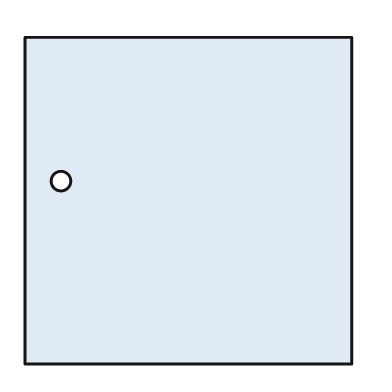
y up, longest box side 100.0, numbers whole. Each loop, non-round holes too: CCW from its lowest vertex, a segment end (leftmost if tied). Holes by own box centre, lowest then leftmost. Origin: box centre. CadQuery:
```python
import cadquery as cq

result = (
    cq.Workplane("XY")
    .moveTo(-50.0, -50.0)
    .lineTo(50.0, -50.0)
    .lineTo(50.0, 50.0)
    .lineTo(-50.0, 50.0)
    .close()
    .moveTo(-39.0, 6.0)
    .circle(3.0)
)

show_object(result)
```